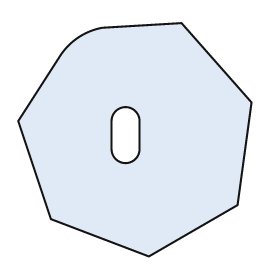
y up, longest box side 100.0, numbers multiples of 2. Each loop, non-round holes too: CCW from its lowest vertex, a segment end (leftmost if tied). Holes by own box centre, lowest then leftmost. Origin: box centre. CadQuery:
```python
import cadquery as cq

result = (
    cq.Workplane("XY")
    .moveTo(6.0, -50.0)
    .lineTo(44.0, -28.0)
    .lineTo(50.0, 16.0)
    .lineTo(20.0, 50.0)
    .lineTo(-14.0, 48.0)
    .threePointArc((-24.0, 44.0), (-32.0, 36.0))
    .lineTo(-50.0, 8.0)
    .lineTo(-36.0, -34.0)
    .close()
    .moveTo(-10.0, -4.0)
    .threePointArc((-4.0, -10.0), (2.0, -4.0))
    .lineTo(2.0, 8.0)
    .threePointArc((-4.0, 14.0), (-10.0, 8.0))
    .close()
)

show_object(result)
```